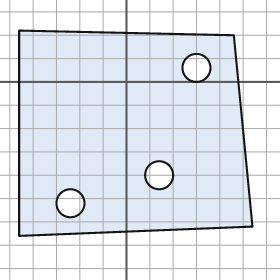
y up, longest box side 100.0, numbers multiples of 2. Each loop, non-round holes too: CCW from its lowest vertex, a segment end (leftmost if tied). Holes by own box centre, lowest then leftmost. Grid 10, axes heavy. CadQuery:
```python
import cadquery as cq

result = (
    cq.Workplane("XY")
    .moveTo(-46.0, -66.0)
    .lineTo(54.0, -62.0)
    .lineTo(46.0, 20.0)
    .lineTo(-46.0, 22.0)
    .close()
    .moveTo(-24.0, -52.0)
    .circle(6.0)
    .moveTo(14.0, -40.0)
    .circle(6.0)
    .moveTo(30.0, 6.0)
    .circle(6.0)
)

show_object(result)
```